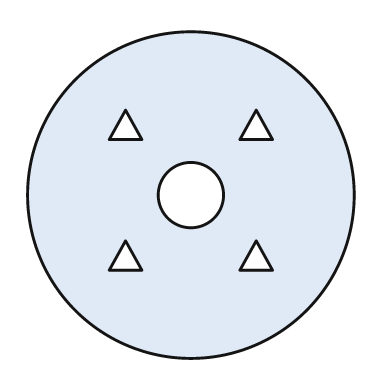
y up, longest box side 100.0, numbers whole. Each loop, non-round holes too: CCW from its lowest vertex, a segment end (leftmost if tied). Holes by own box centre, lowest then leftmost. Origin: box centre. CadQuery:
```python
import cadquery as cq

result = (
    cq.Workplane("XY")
    .moveTo(0.0, 0.0)
    .circle(50.0)
    .moveTo(-25.0, -23.0)
    .lineTo(-15.0, -23.0)
    .lineTo(-20.0, -14.0)
    .close()
    .moveTo(15.0, -23.0)
    .lineTo(25.0, -23.0)
    .lineTo(20.0, -14.0)
    .close()
    .moveTo(0.0, 0.0)
    .circle(10.0)
    .moveTo(-25.0, 17.0)
    .lineTo(-15.0, 17.0)
    .lineTo(-20.0, 26.0)
    .close()
    .moveTo(15.0, 17.0)
    .lineTo(25.0, 17.0)
    .lineTo(20.0, 26.0)
    .close()
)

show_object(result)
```